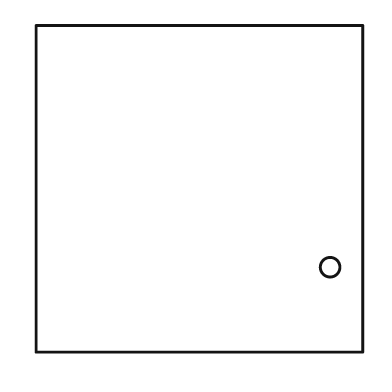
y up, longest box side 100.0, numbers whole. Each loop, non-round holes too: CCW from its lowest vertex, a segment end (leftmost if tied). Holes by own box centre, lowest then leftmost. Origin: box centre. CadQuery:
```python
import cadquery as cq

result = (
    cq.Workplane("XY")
    .moveTo(-50.0, -50.0)
    .lineTo(50.0, -50.0)
    .lineTo(50.0, 50.0)
    .lineTo(-50.0, 50.0)
    .close()
    .moveTo(40.0, -24.0)
    .circle(3.0)
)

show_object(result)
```